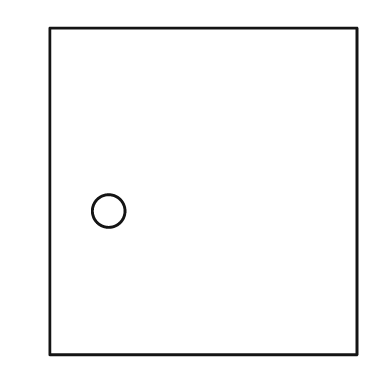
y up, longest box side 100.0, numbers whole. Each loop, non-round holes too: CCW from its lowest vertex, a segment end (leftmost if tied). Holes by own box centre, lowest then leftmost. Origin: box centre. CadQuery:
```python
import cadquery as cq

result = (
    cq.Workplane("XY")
    .moveTo(-47.0, -50.0)
    .lineTo(47.0, -50.0)
    .lineTo(47.0, 50.0)
    .lineTo(-47.0, 50.0)
    .close()
    .moveTo(-29.0, -6.0)
    .circle(5.0)
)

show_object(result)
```